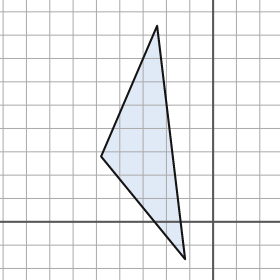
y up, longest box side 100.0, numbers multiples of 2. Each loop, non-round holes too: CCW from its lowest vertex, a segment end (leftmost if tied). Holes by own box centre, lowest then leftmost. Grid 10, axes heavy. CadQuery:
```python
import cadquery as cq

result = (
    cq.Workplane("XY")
    .moveTo(-12.0, -16.0)
    .lineTo(-24.0, 84.0)
    .lineTo(-48.0, 28.0)
    .close()
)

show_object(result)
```